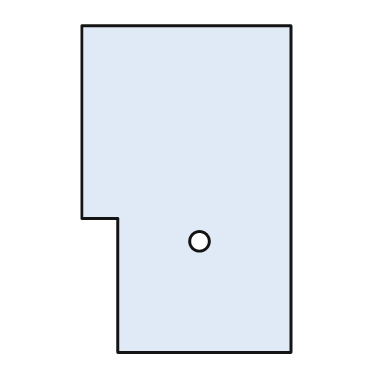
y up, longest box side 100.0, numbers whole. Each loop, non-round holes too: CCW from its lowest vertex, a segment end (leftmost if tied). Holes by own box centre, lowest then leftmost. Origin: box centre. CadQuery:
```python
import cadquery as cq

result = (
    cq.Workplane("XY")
    .moveTo(-21.0, -50.0)
    .lineTo(32.0, -50.0)
    .lineTo(32.0, 50.0)
    .lineTo(-32.0, 50.0)
    .lineTo(-32.0, -9.0)
    .lineTo(-21.0, -9.0)
    .close()
    .moveTo(4.0, -16.0)
    .circle(3.0)
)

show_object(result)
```